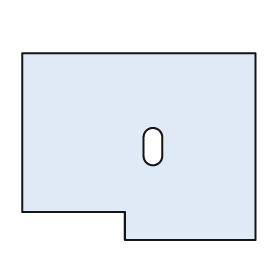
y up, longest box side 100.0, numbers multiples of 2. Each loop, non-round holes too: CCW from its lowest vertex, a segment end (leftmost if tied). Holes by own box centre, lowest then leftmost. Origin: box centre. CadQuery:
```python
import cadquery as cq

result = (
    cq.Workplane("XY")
    .moveTo(-6.0, -40.0)
    .lineTo(50.0, -40.0)
    .lineTo(50.0, 40.0)
    .lineTo(-50.0, 40.0)
    .lineTo(-50.0, -28.0)
    .lineTo(-6.0, -28.0)
    .close()
    .moveTo(2.0, -4.0)
    .threePointArc((6.0, -8.0), (10.0, -4.0))
    .lineTo(10.0, 4.0)
    .threePointArc((6.0, 8.0), (2.0, 4.0))
    .close()
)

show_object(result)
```